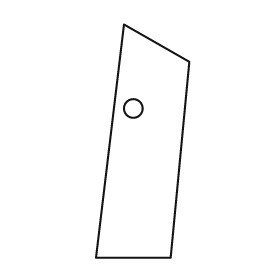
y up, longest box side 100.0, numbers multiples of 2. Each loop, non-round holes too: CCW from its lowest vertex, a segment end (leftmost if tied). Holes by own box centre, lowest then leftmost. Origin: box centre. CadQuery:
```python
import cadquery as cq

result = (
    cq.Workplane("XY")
    .moveTo(-20.0, -50.0)
    .lineTo(12.0, -50.0)
    .lineTo(20.0, 34.0)
    .lineTo(-8.0, 50.0)
    .close()
    .moveTo(-4.0, 14.0)
    .circle(4.0)
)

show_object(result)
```